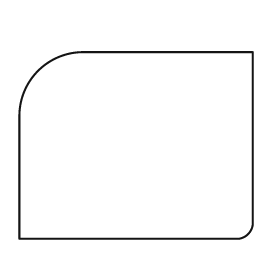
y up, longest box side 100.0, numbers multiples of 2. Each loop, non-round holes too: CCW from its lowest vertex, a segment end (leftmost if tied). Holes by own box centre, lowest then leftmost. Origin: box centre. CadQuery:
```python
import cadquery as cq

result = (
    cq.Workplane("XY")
    .moveTo(-50.0, -40.0)
    .lineTo(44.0, -40.0)
    .threePointArc((48.0, -38.0), (50.0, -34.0))
    .lineTo(50.0, 40.0)
    .lineTo(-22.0, 40.0)
    .threePointArc((-42.0, 32.0), (-50.0, 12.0))
    .close()
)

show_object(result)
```